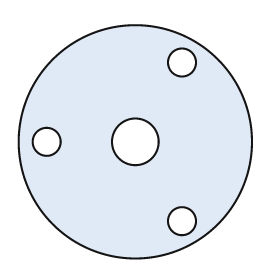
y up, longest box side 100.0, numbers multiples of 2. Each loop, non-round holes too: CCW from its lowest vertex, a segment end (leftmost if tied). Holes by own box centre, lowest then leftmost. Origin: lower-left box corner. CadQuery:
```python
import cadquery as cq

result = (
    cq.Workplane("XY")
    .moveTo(50.0, 50.0)
    .circle(50.0)
    .moveTo(70.0, 16.0)
    .circle(6.0)
    .moveTo(12.0, 50.0)
    .circle(6.0)
    .moveTo(50.0, 50.0)
    .circle(10.0)
    .moveTo(70.0, 84.0)
    .circle(6.0)
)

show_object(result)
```